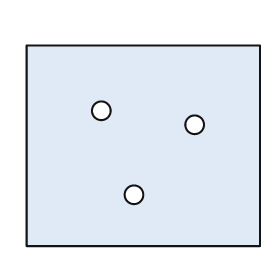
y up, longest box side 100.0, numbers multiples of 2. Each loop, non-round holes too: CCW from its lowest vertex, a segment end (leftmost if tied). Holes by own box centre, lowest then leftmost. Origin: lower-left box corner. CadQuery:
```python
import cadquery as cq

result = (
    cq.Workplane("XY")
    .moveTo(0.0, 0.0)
    .lineTo(100.0, 0.0)
    .lineTo(100.0, 86.0)
    .lineTo(0.0, 86.0)
    .close()
    .moveTo(46.0, 22.0)
    .circle(4.0)
    .moveTo(72.0, 52.0)
    .circle(4.0)
    .moveTo(32.0, 58.0)
    .circle(4.0)
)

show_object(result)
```